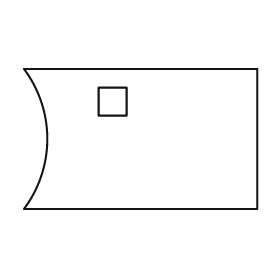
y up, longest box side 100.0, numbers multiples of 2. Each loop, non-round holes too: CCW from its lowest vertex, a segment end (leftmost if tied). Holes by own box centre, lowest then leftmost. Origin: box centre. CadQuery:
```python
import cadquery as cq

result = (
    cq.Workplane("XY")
    .moveTo(-50.0, -30.0)
    .lineTo(50.0, -30.0)
    .lineTo(50.0, 30.0)
    .lineTo(-50.0, 30.0)
    .threePointArc((-40.0, 0.0), (-50.0, -30.0))
    .close()
    .moveTo(-18.0, 10.0)
    .lineTo(-6.0, 10.0)
    .lineTo(-6.0, 22.0)
    .lineTo(-18.0, 22.0)
    .close()
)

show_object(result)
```